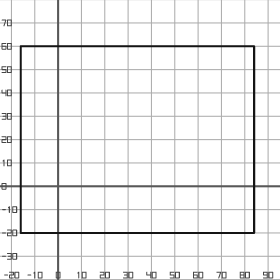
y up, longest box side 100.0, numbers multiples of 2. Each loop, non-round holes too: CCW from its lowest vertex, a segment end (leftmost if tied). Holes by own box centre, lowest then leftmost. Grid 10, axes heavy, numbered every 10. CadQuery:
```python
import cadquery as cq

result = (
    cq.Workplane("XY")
    .moveTo(-16.0, -20.0)
    .lineTo(84.0, -20.0)
    .lineTo(84.0, 60.0)
    .lineTo(-16.0, 60.0)
    .close()
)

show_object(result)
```